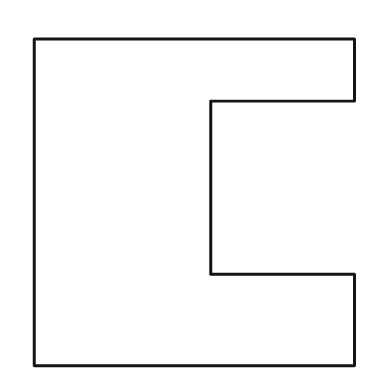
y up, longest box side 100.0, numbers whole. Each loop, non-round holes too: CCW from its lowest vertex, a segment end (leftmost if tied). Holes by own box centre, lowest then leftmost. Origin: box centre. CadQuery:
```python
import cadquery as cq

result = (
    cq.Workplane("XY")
    .moveTo(-49.0, -50.0)
    .lineTo(49.0, -50.0)
    .lineTo(49.0, -22.0)
    .lineTo(5.0, -22.0)
    .lineTo(5.0, 31.0)
    .lineTo(49.0, 31.0)
    .lineTo(49.0, 50.0)
    .lineTo(-49.0, 50.0)
    .close()
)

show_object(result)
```